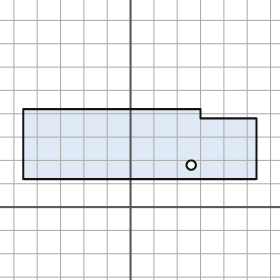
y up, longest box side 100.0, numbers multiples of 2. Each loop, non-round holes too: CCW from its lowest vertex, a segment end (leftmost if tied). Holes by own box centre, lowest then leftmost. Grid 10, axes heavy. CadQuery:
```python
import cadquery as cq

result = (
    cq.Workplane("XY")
    .moveTo(-46.0, 12.0)
    .lineTo(54.0, 12.0)
    .lineTo(54.0, 38.0)
    .lineTo(30.0, 38.0)
    .lineTo(30.0, 42.0)
    .lineTo(-46.0, 42.0)
    .close()
    .moveTo(26.0, 18.0)
    .circle(2.0)
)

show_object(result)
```